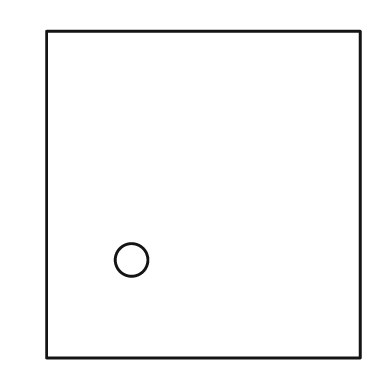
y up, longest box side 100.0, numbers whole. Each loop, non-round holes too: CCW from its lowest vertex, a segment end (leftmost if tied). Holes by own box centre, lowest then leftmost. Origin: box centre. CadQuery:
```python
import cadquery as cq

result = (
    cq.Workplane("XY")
    .moveTo(-48.0, -50.0)
    .lineTo(48.0, -50.0)
    .lineTo(48.0, 50.0)
    .lineTo(-48.0, 50.0)
    .close()
    .moveTo(-22.0, -20.0)
    .circle(5.0)
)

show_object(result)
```